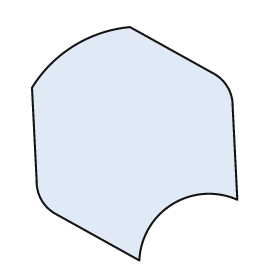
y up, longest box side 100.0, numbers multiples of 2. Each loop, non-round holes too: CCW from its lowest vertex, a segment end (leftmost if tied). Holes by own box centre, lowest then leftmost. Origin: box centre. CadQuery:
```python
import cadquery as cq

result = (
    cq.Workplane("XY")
    .moveTo(2.0, -50.0)
    .threePointArc((16.0, -26.0), (44.0, -24.0))
    .lineTo(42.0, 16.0)
    .threePointArc((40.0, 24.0), (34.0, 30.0))
    .lineTo(-2.0, 50.0)
    .threePointArc((-26.0, 42.0), (-44.0, 24.0))
    .lineTo(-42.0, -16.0)
    .threePointArc((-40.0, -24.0), (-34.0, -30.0))
    .close()
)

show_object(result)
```